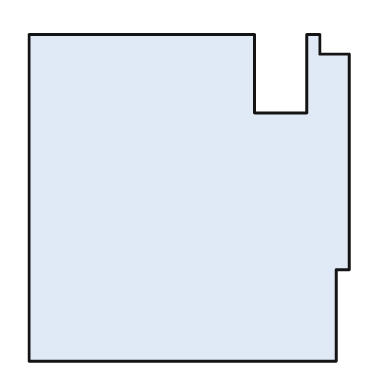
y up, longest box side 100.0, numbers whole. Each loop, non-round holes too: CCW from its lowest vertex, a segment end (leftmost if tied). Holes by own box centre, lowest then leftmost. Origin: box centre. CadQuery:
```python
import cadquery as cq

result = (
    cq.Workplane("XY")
    .moveTo(-49.0, -50.0)
    .lineTo(45.0, -50.0)
    .lineTo(45.0, -22.0)
    .lineTo(49.0, -22.0)
    .lineTo(49.0, 44.0)
    .lineTo(40.0, 44.0)
    .lineTo(40.0, 50.0)
    .lineTo(36.0, 50.0)
    .lineTo(36.0, 26.0)
    .lineTo(20.0, 26.0)
    .lineTo(20.0, 50.0)
    .lineTo(-49.0, 50.0)
    .close()
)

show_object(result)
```